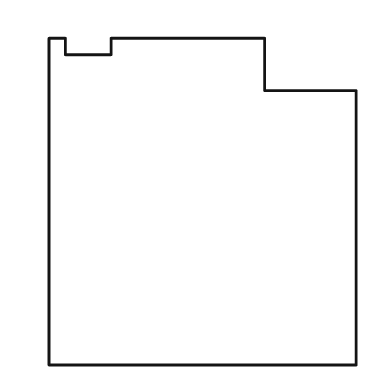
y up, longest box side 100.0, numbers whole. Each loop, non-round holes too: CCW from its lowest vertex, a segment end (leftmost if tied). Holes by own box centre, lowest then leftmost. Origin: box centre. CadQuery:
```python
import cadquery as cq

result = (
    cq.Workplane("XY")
    .moveTo(-47.0, -50.0)
    .lineTo(47.0, -50.0)
    .lineTo(47.0, 34.0)
    .lineTo(19.0, 34.0)
    .lineTo(19.0, 50.0)
    .lineTo(-28.0, 50.0)
    .lineTo(-28.0, 45.0)
    .lineTo(-42.0, 45.0)
    .lineTo(-42.0, 50.0)
    .lineTo(-47.0, 50.0)
    .close()
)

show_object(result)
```